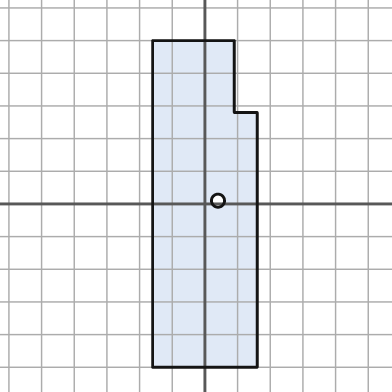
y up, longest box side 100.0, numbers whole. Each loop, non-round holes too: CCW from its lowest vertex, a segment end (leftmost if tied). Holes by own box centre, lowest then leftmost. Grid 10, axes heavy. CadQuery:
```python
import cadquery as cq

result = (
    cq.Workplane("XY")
    .moveTo(-16.0, -50.0)
    .lineTo(16.0, -50.0)
    .lineTo(16.0, 28.0)
    .lineTo(9.0, 28.0)
    .lineTo(9.0, 50.0)
    .lineTo(-16.0, 50.0)
    .close()
    .moveTo(4.0, 1.0)
    .circle(2.0)
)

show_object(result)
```